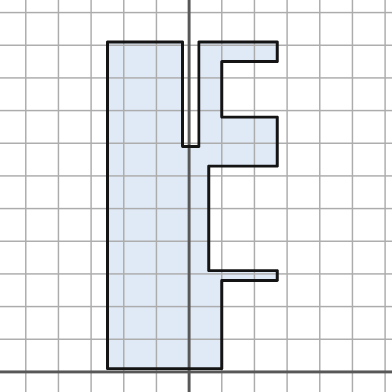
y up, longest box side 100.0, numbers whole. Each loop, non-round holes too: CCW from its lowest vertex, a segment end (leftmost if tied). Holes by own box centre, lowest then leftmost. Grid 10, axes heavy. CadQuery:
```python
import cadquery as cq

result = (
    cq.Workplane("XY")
    .moveTo(-25.0, 1.0)
    .lineTo(10.0, 1.0)
    .lineTo(10.0, 28.0)
    .lineTo(27.0, 28.0)
    .lineTo(27.0, 31.0)
    .lineTo(6.0, 31.0)
    .lineTo(6.0, 63.0)
    .lineTo(27.0, 63.0)
    .lineTo(27.0, 78.0)
    .lineTo(10.0, 78.0)
    .lineTo(10.0, 95.0)
    .lineTo(27.0, 95.0)
    .lineTo(27.0, 101.0)
    .lineTo(3.0, 101.0)
    .lineTo(3.0, 69.0)
    .lineTo(-2.0, 69.0)
    .lineTo(-2.0, 101.0)
    .lineTo(-25.0, 101.0)
    .close()
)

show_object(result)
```